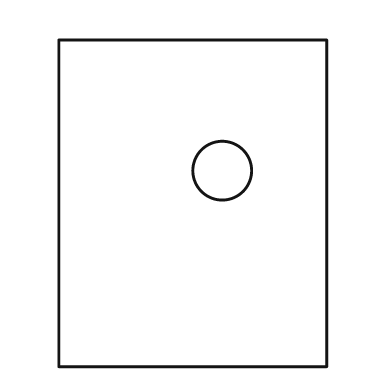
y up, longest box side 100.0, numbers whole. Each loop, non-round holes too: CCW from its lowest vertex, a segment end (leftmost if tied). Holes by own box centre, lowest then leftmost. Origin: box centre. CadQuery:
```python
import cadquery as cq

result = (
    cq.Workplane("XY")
    .moveTo(-41.0, -50.0)
    .lineTo(41.0, -50.0)
    .lineTo(41.0, 50.0)
    .lineTo(-41.0, 50.0)
    .close()
    .moveTo(9.0, 10.0)
    .circle(9.0)
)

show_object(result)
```